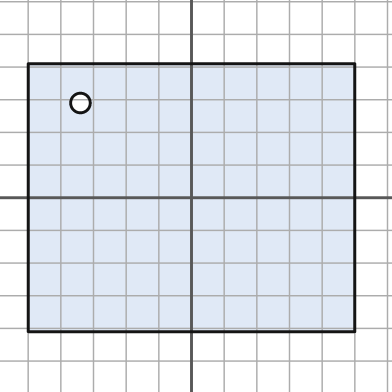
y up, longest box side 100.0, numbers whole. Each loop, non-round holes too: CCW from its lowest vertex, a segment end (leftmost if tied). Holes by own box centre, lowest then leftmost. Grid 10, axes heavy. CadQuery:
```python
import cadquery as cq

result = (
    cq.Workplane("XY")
    .moveTo(-50.0, -41.0)
    .lineTo(50.0, -41.0)
    .lineTo(50.0, 41.0)
    .lineTo(-50.0, 41.0)
    .close()
    .moveTo(-34.0, 29.0)
    .circle(3.0)
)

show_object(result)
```